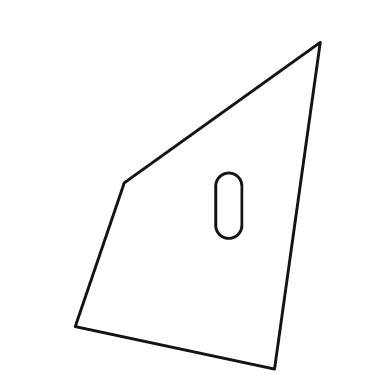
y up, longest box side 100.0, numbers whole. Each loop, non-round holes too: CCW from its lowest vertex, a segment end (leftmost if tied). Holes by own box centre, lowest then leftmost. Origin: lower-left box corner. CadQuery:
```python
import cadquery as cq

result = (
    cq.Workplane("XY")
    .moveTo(61.0, 0.0)
    .lineTo(75.0, 100.0)
    .lineTo(15.0, 57.0)
    .lineTo(0.0, 13.0)
    .close()
    .moveTo(43.0, 44.0)
    .threePointArc((47.0, 40.0), (51.0, 44.0))
    .lineTo(51.0, 56.0)
    .threePointArc((47.0, 60.0), (43.0, 56.0))
    .close()
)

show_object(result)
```